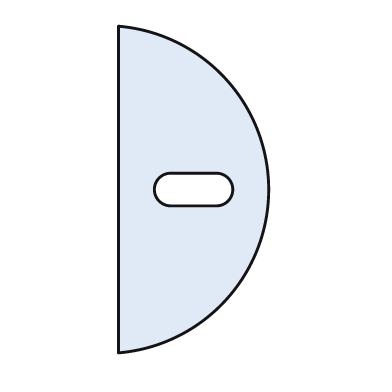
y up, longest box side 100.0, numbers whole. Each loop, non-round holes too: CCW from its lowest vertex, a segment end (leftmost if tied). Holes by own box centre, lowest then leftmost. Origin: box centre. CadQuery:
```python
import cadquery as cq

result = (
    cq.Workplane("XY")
    .moveTo(-23.0, -50.0)
    .threePointArc((23.0, 0.0), (-23.0, 50.0))
    .close()
    .moveTo(-7.0, -5.0)
    .lineTo(7.0, -5.0)
    .threePointArc((12.0, 0.0), (7.0, 5.0))
    .lineTo(-7.0, 5.0)
    .threePointArc((-12.0, 0.0), (-7.0, -5.0))
    .close()
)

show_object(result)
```